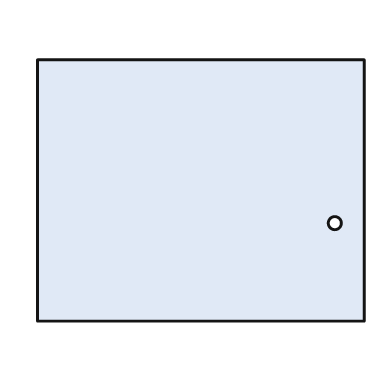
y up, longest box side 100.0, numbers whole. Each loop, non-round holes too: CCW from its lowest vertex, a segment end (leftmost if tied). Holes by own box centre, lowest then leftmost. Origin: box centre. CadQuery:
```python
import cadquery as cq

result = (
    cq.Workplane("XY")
    .moveTo(-50.0, -40.0)
    .lineTo(50.0, -40.0)
    .lineTo(50.0, 40.0)
    .lineTo(-50.0, 40.0)
    .close()
    .moveTo(41.0, -10.0)
    .circle(2.0)
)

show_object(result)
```